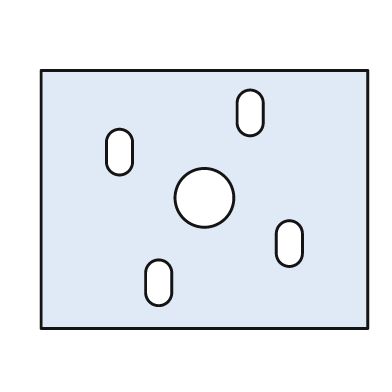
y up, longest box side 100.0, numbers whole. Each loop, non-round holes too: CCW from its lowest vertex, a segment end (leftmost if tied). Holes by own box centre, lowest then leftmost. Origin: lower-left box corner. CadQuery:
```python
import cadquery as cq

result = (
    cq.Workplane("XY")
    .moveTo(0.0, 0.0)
    .lineTo(100.0, 0.0)
    .lineTo(100.0, 79.0)
    .lineTo(0.0, 79.0)
    .close()
    .moveTo(32.0, 11.0)
    .threePointArc((36.0, 7.0), (40.0, 11.0))
    .lineTo(40.0, 17.0)
    .threePointArc((36.0, 21.0), (32.0, 17.0))
    .close()
    .moveTo(72.0, 23.0)
    .threePointArc((76.0, 19.0), (80.0, 23.0))
    .lineTo(80.0, 29.0)
    .threePointArc((76.0, 33.0), (72.0, 29.0))
    .close()
    .moveTo(50.0, 40.0)
    .circle(9.0)
    .moveTo(20.0, 51.0)
    .threePointArc((24.0, 47.0), (28.0, 51.0))
    .lineTo(28.0, 57.0)
    .threePointArc((24.0, 61.0), (20.0, 57.0))
    .close()
    .moveTo(60.0, 63.0)
    .threePointArc((64.0, 59.0), (68.0, 63.0))
    .lineTo(68.0, 69.0)
    .threePointArc((64.0, 73.0), (60.0, 69.0))
    .close()
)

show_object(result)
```